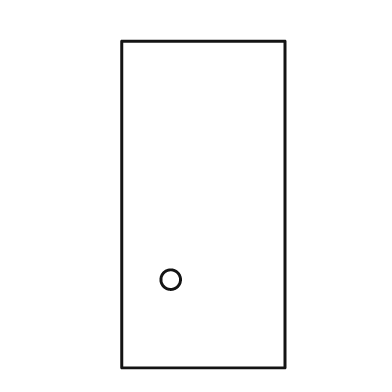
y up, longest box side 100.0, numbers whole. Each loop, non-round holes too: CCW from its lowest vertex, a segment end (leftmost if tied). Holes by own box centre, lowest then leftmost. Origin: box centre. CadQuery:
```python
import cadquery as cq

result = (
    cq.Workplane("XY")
    .moveTo(-25.0, -50.0)
    .lineTo(25.0, -50.0)
    .lineTo(25.0, 50.0)
    .lineTo(-25.0, 50.0)
    .close()
    .moveTo(-10.0, -23.0)
    .circle(3.0)
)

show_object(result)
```